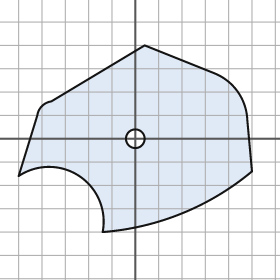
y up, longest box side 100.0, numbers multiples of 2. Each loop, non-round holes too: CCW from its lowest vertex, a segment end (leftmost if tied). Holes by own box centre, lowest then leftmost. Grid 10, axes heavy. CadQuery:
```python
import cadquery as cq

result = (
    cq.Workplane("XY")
    .moveTo(-14.0, -40.0)
    .threePointArc((20.0, -32.0), (50.0, -14.0))
    .lineTo(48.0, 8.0)
    .threePointArc((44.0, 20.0), (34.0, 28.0))
    .lineTo(4.0, 40.0)
    .lineTo(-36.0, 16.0)
    .threePointArc((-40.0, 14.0), (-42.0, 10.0))
    .lineTo(-50.0, -16.0)
    .threePointArc((-24.0, -16.0), (-14.0, -40.0))
    .close()
    .moveTo(0.0, 0.0)
    .circle(4.0)
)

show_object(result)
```